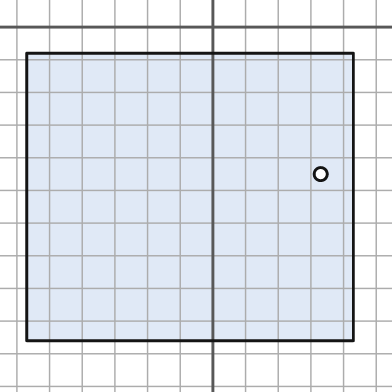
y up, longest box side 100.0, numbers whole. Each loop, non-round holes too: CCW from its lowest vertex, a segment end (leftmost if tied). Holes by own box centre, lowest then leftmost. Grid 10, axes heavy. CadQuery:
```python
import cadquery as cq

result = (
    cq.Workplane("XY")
    .moveTo(-57.0, -96.0)
    .lineTo(43.0, -96.0)
    .lineTo(43.0, -8.0)
    .lineTo(-57.0, -8.0)
    .close()
    .moveTo(33.0, -45.0)
    .circle(2.0)
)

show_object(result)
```